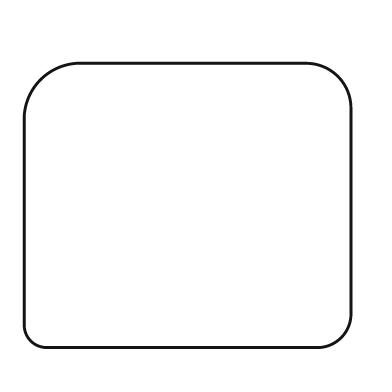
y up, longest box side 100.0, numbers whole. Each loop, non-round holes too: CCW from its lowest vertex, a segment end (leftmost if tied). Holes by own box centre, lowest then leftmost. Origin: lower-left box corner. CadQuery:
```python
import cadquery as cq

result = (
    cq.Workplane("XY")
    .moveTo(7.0, 0.0)
    .lineTo(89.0, 0.0)
    .threePointArc((97.0, 3.0), (100.0, 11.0))
    .lineTo(100.0, 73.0)
    .threePointArc((96.0, 83.0), (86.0, 87.0))
    .lineTo(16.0, 87.0)
    .threePointArc((5.0, 82.0), (0.0, 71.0))
    .lineTo(0.0, 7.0)
    .threePointArc((2.0, 2.0), (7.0, 0.0))
    .close()
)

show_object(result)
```